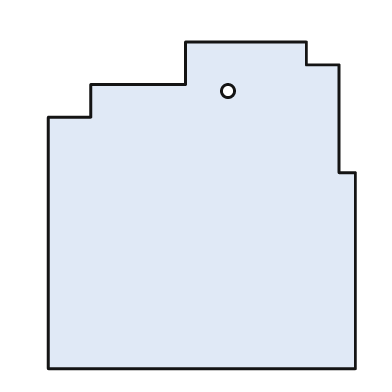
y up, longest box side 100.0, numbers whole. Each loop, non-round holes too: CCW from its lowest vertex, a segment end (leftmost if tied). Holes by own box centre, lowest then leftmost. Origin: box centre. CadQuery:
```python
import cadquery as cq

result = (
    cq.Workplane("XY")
    .moveTo(-47.0, -50.0)
    .lineTo(47.0, -50.0)
    .lineTo(47.0, 10.0)
    .lineTo(42.0, 10.0)
    .lineTo(42.0, 43.0)
    .lineTo(32.0, 43.0)
    .lineTo(32.0, 50.0)
    .lineTo(-5.0, 50.0)
    .lineTo(-5.0, 37.0)
    .lineTo(-34.0, 37.0)
    .lineTo(-34.0, 27.0)
    .lineTo(-47.0, 27.0)
    .close()
    .moveTo(8.0, 35.0)
    .circle(2.0)
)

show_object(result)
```